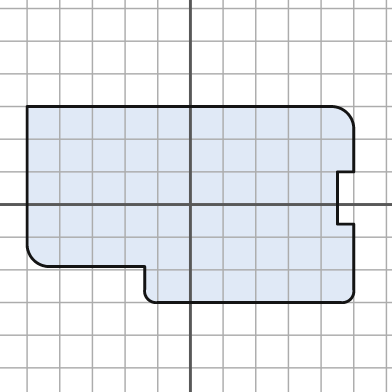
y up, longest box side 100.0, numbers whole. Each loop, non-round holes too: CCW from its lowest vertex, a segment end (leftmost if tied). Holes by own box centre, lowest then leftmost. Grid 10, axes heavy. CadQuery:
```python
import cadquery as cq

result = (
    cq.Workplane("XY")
    .moveTo(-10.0, -30.0)
    .lineTo(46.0, -30.0)
    .threePointArc((49.0, -29.0), (50.0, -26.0))
    .lineTo(50.0, -6.0)
    .lineTo(45.0, -6.0)
    .lineTo(45.0, 10.0)
    .lineTo(50.0, 10.0)
    .lineTo(50.0, 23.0)
    .threePointArc((48.0, 28.0), (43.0, 30.0))
    .lineTo(-50.0, 30.0)
    .lineTo(-50.0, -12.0)
    .threePointArc((-48.0, -17.0), (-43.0, -19.0))
    .lineTo(-14.0, -19.0)
    .lineTo(-14.0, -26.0)
    .threePointArc((-13.0, -29.0), (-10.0, -30.0))
    .close()
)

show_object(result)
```